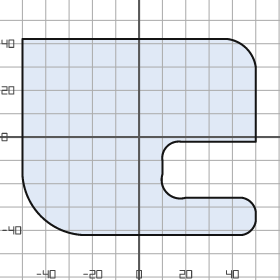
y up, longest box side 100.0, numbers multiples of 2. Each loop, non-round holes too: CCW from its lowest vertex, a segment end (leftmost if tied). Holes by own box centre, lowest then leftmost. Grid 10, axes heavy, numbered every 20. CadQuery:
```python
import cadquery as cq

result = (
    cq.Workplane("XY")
    .moveTo(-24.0, -42.0)
    .lineTo(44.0, -42.0)
    .threePointArc((48.0, -40.0), (50.0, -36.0))
    .lineTo(50.0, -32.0)
    .threePointArc((48.0, -28.0), (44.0, -26.0))
    .lineTo(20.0, -26.0)
    .threePointArc((12.0, -24.0), (10.0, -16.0))
    .lineTo(10.0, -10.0)
    .threePointArc((12.0, -4.0), (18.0, -2.0))
    .lineTo(50.0, -2.0)
    .lineTo(50.0, 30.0)
    .threePointArc((46.0, 38.0), (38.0, 42.0))
    .lineTo(-50.0, 42.0)
    .lineTo(-50.0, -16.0)
    .threePointArc((-42.0, -34.0), (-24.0, -42.0))
    .close()
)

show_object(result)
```